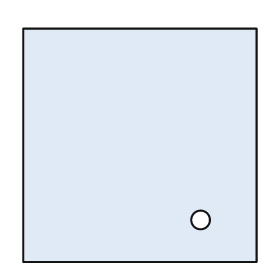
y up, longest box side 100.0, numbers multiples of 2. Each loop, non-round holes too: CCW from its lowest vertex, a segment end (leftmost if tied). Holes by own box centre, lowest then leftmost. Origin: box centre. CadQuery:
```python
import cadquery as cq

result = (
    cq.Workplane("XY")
    .moveTo(-50.0, -50.0)
    .lineTo(50.0, -50.0)
    .lineTo(50.0, 50.0)
    .lineTo(-50.0, 50.0)
    .close()
    .moveTo(26.0, -32.0)
    .circle(4.0)
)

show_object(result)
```